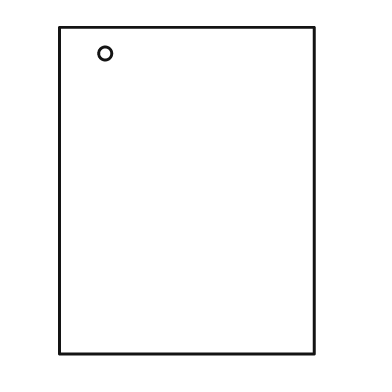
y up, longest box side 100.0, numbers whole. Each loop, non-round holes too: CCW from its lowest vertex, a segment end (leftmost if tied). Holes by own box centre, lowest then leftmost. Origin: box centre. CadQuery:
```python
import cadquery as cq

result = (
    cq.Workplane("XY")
    .moveTo(-39.0, -50.0)
    .lineTo(39.0, -50.0)
    .lineTo(39.0, 50.0)
    .lineTo(-39.0, 50.0)
    .close()
    .moveTo(-25.0, 42.0)
    .circle(2.0)
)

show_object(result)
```